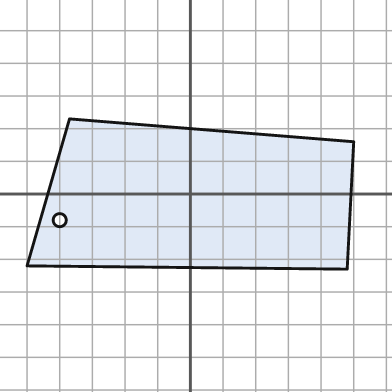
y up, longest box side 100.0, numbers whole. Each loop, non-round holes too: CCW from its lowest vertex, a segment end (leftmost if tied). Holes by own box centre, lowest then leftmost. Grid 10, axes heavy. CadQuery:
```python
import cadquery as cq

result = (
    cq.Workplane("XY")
    .moveTo(48.0, -23.0)
    .lineTo(50.0, 16.0)
    .lineTo(-37.0, 23.0)
    .lineTo(-50.0, -22.0)
    .close()
    .moveTo(-40.0, -8.0)
    .circle(2.0)
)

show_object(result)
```